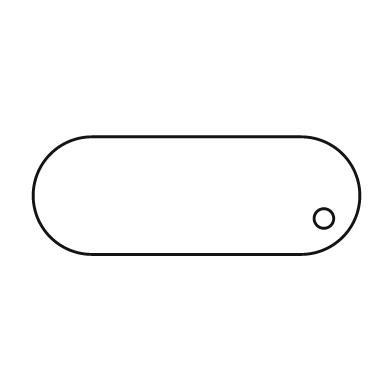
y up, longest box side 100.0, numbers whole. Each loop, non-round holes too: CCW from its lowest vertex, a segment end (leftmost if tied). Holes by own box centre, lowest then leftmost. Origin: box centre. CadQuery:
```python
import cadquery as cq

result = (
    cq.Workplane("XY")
    .moveTo(-32.0, -18.0)
    .lineTo(32.0, -18.0)
    .threePointArc((50.0, 0.0), (32.0, 18.0))
    .lineTo(-32.0, 18.0)
    .threePointArc((-50.0, 0.0), (-32.0, -18.0))
    .close()
    .moveTo(39.0, -7.0)
    .circle(3.0)
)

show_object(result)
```